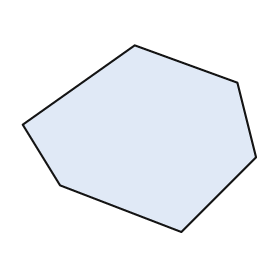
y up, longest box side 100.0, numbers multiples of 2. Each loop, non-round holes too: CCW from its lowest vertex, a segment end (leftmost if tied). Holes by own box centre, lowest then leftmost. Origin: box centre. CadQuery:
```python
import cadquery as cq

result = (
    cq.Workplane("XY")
    .moveTo(18.0, -40.0)
    .lineTo(50.0, -8.0)
    .lineTo(42.0, 24.0)
    .lineTo(-2.0, 40.0)
    .lineTo(-50.0, 6.0)
    .lineTo(-34.0, -20.0)
    .close()
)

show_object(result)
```